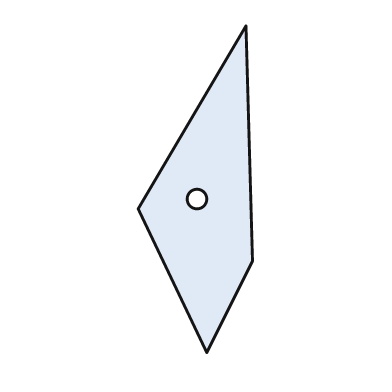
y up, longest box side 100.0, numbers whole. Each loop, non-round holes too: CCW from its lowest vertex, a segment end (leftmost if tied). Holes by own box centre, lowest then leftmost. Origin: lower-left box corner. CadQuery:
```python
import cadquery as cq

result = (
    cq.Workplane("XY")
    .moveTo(21.0, 0.0)
    .lineTo(35.0, 28.0)
    .lineTo(33.0, 100.0)
    .lineTo(0.0, 44.0)
    .close()
    .moveTo(18.0, 47.0)
    .circle(3.0)
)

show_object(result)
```